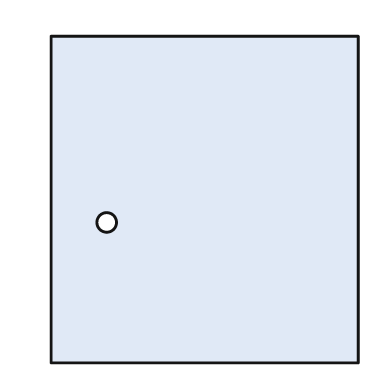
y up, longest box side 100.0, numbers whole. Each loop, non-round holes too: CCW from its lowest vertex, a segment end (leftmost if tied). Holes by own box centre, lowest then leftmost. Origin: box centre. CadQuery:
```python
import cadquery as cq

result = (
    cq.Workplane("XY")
    .moveTo(-47.0, -50.0)
    .lineTo(47.0, -50.0)
    .lineTo(47.0, 50.0)
    .lineTo(-47.0, 50.0)
    .close()
    .moveTo(-30.0, -7.0)
    .circle(3.0)
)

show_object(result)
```